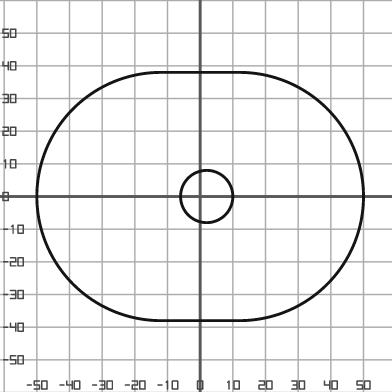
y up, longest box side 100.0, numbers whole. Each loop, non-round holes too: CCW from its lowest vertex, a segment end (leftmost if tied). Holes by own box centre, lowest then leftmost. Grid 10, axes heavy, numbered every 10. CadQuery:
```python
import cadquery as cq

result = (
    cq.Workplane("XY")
    .moveTo(-12.0, -38.0)
    .lineTo(12.0, -38.0)
    .threePointArc((50.0, 0.0), (12.0, 38.0))
    .lineTo(-12.0, 38.0)
    .threePointArc((-50.0, 0.0), (-12.0, -38.0))
    .close()
    .moveTo(2.0, 0.0)
    .circle(8.0)
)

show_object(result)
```